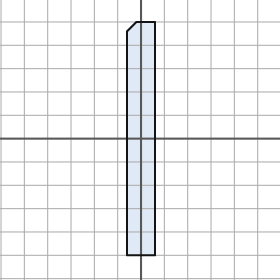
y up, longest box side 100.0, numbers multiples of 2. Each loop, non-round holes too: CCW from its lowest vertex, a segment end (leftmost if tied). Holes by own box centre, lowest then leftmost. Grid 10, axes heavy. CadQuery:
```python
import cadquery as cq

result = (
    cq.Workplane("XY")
    .moveTo(-6.0, -50.0)
    .lineTo(6.0, -50.0)
    .lineTo(6.0, 50.0)
    .lineTo(-2.0, 50.0)
    .lineTo(-6.0, 46.0)
    .close()
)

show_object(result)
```